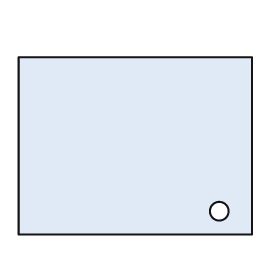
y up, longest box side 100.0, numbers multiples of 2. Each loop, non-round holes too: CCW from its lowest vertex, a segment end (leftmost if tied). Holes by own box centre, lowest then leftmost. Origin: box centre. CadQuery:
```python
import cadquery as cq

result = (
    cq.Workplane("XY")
    .moveTo(-50.0, -38.0)
    .lineTo(50.0, -38.0)
    .lineTo(50.0, 38.0)
    .lineTo(-50.0, 38.0)
    .close()
    .moveTo(36.0, -28.0)
    .circle(4.0)
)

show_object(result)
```